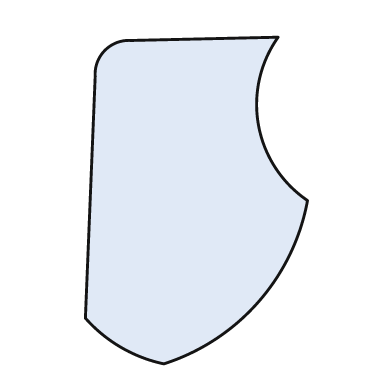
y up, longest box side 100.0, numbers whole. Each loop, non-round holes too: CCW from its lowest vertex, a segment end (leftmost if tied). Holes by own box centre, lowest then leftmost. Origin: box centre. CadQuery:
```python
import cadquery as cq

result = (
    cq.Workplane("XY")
    .moveTo(-10.0, -50.0)
    .threePointArc((19.0, -31.0), (34.0, 0.0))
    .threePointArc((19.0, 23.0), (25.0, 50.0))
    .lineTo(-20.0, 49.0)
    .threePointArc((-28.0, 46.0), (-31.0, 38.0))
    .lineTo(-34.0, -36.0)
    .threePointArc((-23.0, -45.0), (-10.0, -50.0))
    .close()
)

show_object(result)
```